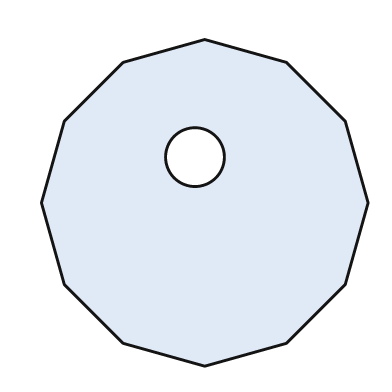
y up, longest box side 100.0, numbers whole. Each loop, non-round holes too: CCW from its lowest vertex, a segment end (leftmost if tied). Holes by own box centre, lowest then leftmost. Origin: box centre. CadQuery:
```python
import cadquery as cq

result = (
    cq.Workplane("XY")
    .moveTo(0.0, -50.0)
    .lineTo(25.0, -43.0)
    .lineTo(43.0, -25.0)
    .lineTo(50.0, 0.0)
    .lineTo(43.0, 25.0)
    .lineTo(25.0, 43.0)
    .lineTo(0.0, 50.0)
    .lineTo(-25.0, 43.0)
    .lineTo(-43.0, 25.0)
    .lineTo(-50.0, 0.0)
    .lineTo(-43.0, -25.0)
    .lineTo(-25.0, -43.0)
    .close()
    .moveTo(-3.0, 14.0)
    .circle(9.0)
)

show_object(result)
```